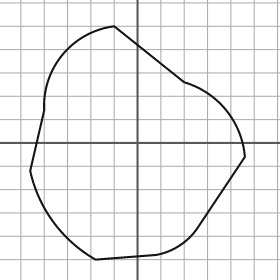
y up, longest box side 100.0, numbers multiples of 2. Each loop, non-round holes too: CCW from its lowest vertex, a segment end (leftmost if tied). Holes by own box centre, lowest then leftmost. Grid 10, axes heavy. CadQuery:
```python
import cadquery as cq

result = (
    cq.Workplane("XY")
    .moveTo(-18.0, -50.0)
    .lineTo(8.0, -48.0)
    .threePointArc((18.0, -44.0), (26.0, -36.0))
    .lineTo(46.0, -6.0)
    .threePointArc((38.0, 14.0), (20.0, 26.0))
    .lineTo(-10.0, 50.0)
    .threePointArc((-32.0, 38.0), (-40.0, 14.0))
    .lineTo(-46.0, -12.0)
    .threePointArc((-36.0, -34.0), (-18.0, -50.0))
    .close()
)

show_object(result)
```